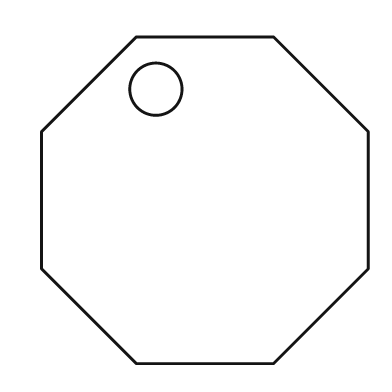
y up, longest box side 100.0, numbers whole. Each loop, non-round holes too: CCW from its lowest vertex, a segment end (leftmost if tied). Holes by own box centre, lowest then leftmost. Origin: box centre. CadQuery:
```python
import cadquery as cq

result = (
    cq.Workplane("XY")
    .moveTo(-21.0, -50.0)
    .lineTo(21.0, -50.0)
    .lineTo(50.0, -21.0)
    .lineTo(50.0, 21.0)
    .lineTo(21.0, 50.0)
    .lineTo(-21.0, 50.0)
    .lineTo(-50.0, 21.0)
    .lineTo(-50.0, -21.0)
    .close()
    .moveTo(-15.0, 34.0)
    .circle(8.0)
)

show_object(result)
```